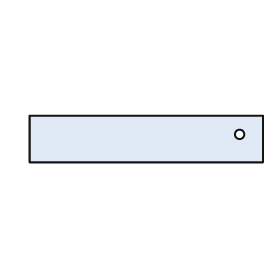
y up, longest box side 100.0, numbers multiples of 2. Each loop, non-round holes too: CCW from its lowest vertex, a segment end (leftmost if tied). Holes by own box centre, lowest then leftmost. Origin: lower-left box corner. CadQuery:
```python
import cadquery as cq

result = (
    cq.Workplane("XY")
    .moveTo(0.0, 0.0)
    .lineTo(100.0, 0.0)
    .lineTo(100.0, 20.0)
    .lineTo(0.0, 20.0)
    .close()
    .moveTo(90.0, 12.0)
    .circle(2.0)
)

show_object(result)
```